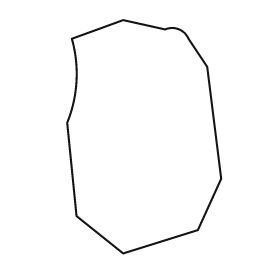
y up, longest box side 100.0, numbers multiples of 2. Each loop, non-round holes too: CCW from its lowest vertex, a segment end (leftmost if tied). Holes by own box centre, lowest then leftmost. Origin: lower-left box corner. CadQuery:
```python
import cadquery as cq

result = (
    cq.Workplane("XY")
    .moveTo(24.0, 0.0)
    .lineTo(56.0, 10.0)
    .lineTo(66.0, 32.0)
    .lineTo(60.0, 80.0)
    .lineTo(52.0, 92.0)
    .threePointArc((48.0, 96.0), (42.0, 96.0))
    .lineTo(24.0, 100.0)
    .lineTo(2.0, 92.0)
    .threePointArc((4.0, 74.0), (0.0, 56.0))
    .lineTo(4.0, 16.0)
    .close()
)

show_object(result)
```